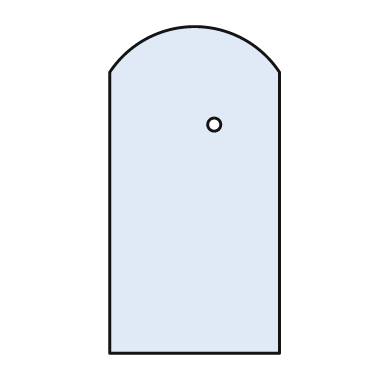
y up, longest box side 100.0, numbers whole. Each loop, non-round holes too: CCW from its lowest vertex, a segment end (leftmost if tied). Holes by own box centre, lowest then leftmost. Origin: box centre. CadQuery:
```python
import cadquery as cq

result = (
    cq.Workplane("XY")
    .moveTo(-26.0, -50.0)
    .lineTo(26.0, -50.0)
    .lineTo(26.0, 36.0)
    .threePointArc((0.0, 50.0), (-26.0, 36.0))
    .close()
    .moveTo(6.0, 20.0)
    .circle(2.0)
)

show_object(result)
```